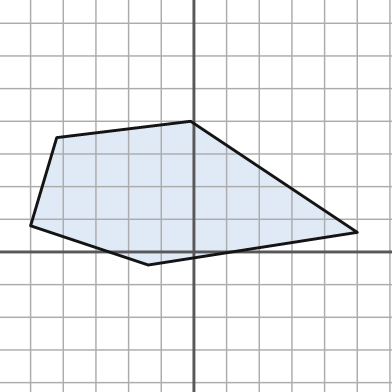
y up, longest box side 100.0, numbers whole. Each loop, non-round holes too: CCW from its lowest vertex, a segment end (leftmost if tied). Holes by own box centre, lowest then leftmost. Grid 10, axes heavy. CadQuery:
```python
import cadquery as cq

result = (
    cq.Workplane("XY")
    .moveTo(-14.0, -4.0)
    .lineTo(50.0, 6.0)
    .lineTo(-1.0, 40.0)
    .lineTo(-42.0, 35.0)
    .lineTo(-50.0, 8.0)
    .close()
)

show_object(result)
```